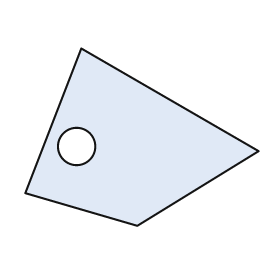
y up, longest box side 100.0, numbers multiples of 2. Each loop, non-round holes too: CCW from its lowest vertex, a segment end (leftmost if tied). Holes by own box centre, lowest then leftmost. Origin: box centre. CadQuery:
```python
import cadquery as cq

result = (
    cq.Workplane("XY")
    .moveTo(-2.0, -38.0)
    .lineTo(50.0, -6.0)
    .lineTo(-26.0, 38.0)
    .lineTo(-50.0, -24.0)
    .close()
    .moveTo(-28.0, -4.0)
    .circle(8.0)
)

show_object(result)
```